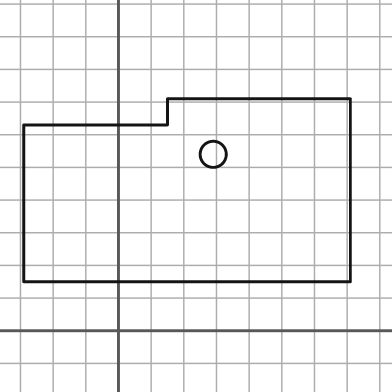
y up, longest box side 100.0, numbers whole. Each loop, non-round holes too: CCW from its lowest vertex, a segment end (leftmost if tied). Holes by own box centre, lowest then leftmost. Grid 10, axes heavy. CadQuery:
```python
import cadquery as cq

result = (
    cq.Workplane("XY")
    .moveTo(-29.0, 15.0)
    .lineTo(71.0, 15.0)
    .lineTo(71.0, 71.0)
    .lineTo(15.0, 71.0)
    .lineTo(15.0, 63.0)
    .lineTo(-29.0, 63.0)
    .close()
    .moveTo(29.0, 54.0)
    .circle(4.0)
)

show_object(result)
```